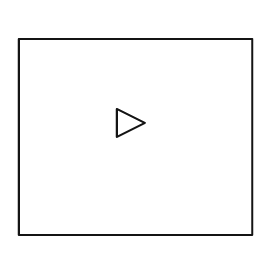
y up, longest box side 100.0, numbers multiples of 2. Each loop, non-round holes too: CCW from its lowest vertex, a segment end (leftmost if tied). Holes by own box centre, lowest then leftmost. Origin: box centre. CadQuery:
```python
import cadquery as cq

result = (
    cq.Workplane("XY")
    .moveTo(-50.0, -42.0)
    .lineTo(50.0, -42.0)
    .lineTo(50.0, 42.0)
    .lineTo(-50.0, 42.0)
    .close()
    .moveTo(-8.0, 0.0)
    .lineTo(4.0, 6.0)
    .lineTo(-8.0, 12.0)
    .close()
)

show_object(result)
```